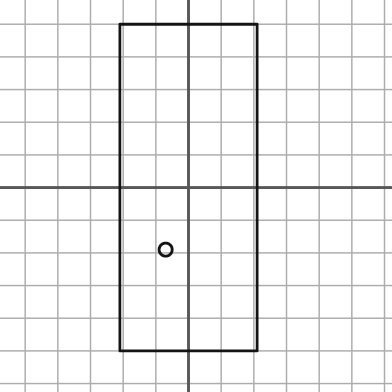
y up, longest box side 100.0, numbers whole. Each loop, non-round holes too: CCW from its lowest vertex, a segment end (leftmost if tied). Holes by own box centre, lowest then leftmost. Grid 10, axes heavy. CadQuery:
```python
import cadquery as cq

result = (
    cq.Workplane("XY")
    .moveTo(-21.0, -50.0)
    .lineTo(21.0, -50.0)
    .lineTo(21.0, 50.0)
    .lineTo(-21.0, 50.0)
    .close()
    .moveTo(-7.0, -19.0)
    .circle(2.0)
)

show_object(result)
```